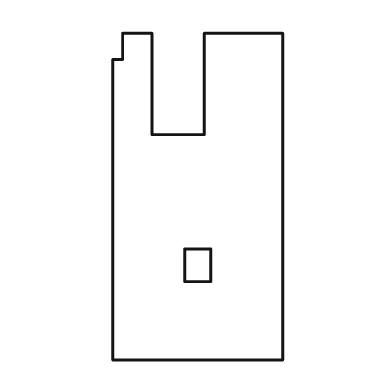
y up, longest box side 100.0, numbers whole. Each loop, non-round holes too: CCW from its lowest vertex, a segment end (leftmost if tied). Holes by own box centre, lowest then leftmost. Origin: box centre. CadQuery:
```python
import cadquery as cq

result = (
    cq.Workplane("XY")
    .moveTo(-26.0, -50.0)
    .lineTo(26.0, -50.0)
    .lineTo(26.0, 50.0)
    .lineTo(2.0, 50.0)
    .lineTo(2.0, 19.0)
    .lineTo(-14.0, 19.0)
    .lineTo(-14.0, 50.0)
    .lineTo(-23.0, 50.0)
    .lineTo(-23.0, 42.0)
    .lineTo(-26.0, 42.0)
    .close()
    .moveTo(-4.0, -26.0)
    .lineTo(4.0, -26.0)
    .lineTo(4.0, -16.0)
    .lineTo(-4.0, -16.0)
    .close()
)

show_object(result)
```